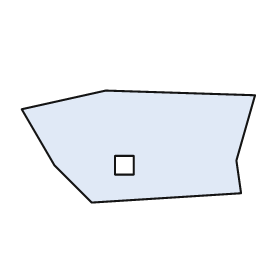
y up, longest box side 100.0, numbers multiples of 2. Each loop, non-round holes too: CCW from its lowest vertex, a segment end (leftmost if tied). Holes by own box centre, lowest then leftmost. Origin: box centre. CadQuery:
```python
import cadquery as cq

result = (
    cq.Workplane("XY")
    .moveTo(-20.0, -24.0)
    .lineTo(44.0, -20.0)
    .lineTo(42.0, -6.0)
    .lineTo(50.0, 22.0)
    .lineTo(-14.0, 24.0)
    .lineTo(-50.0, 16.0)
    .lineTo(-36.0, -8.0)
    .close()
    .moveTo(-10.0, -12.0)
    .lineTo(-2.0, -12.0)
    .lineTo(-2.0, -4.0)
    .lineTo(-10.0, -4.0)
    .close()
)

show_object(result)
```